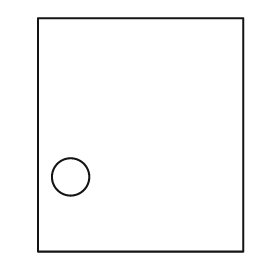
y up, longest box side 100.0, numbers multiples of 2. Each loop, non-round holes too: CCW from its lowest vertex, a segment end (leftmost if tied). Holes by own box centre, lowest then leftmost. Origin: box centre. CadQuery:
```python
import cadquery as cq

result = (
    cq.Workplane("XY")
    .moveTo(-44.0, -50.0)
    .lineTo(44.0, -50.0)
    .lineTo(44.0, 50.0)
    .lineTo(-44.0, 50.0)
    .close()
    .moveTo(-30.0, -18.0)
    .circle(8.0)
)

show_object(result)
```